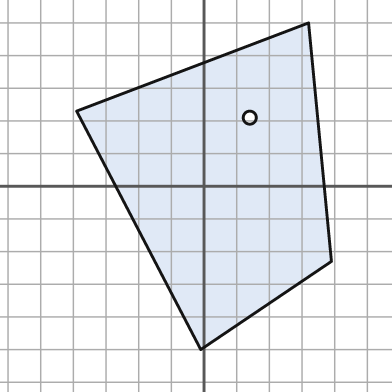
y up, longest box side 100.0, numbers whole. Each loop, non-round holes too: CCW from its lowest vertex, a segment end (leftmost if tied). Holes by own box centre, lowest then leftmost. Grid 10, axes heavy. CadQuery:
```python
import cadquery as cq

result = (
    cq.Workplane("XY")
    .moveTo(-1.0, -50.0)
    .lineTo(39.0, -23.0)
    .lineTo(32.0, 50.0)
    .lineTo(-39.0, 23.0)
    .close()
    .moveTo(14.0, 21.0)
    .circle(2.0)
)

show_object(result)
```